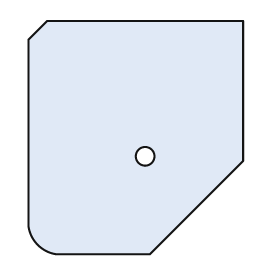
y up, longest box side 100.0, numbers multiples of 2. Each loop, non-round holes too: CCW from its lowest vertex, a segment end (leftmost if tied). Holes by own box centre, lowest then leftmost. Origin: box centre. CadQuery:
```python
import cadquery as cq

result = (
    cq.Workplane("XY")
    .moveTo(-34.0, -50.0)
    .lineTo(6.0, -50.0)
    .lineTo(46.0, -10.0)
    .lineTo(46.0, 50.0)
    .lineTo(-38.0, 50.0)
    .lineTo(-46.0, 42.0)
    .lineTo(-46.0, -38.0)
    .threePointArc((-42.0, -46.0), (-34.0, -50.0))
    .close()
    .moveTo(4.0, -8.0)
    .circle(4.0)
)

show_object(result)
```